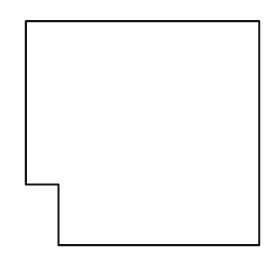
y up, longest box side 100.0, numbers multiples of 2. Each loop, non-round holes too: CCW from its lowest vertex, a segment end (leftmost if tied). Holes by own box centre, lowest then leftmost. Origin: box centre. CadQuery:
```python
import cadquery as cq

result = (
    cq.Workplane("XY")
    .moveTo(-36.0, -48.0)
    .lineTo(50.0, -48.0)
    .lineTo(50.0, 48.0)
    .lineTo(-50.0, 48.0)
    .lineTo(-50.0, -22.0)
    .lineTo(-36.0, -22.0)
    .close()
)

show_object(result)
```